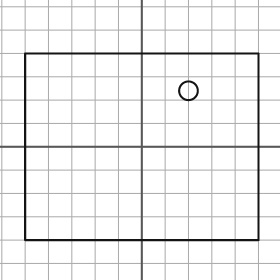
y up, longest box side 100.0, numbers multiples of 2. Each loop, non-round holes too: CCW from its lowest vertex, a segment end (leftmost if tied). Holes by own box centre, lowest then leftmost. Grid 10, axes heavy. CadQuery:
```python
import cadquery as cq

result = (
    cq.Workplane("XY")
    .moveTo(-50.0, -40.0)
    .lineTo(50.0, -40.0)
    .lineTo(50.0, 40.0)
    .lineTo(-50.0, 40.0)
    .close()
    .moveTo(20.0, 24.0)
    .circle(4.0)
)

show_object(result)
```